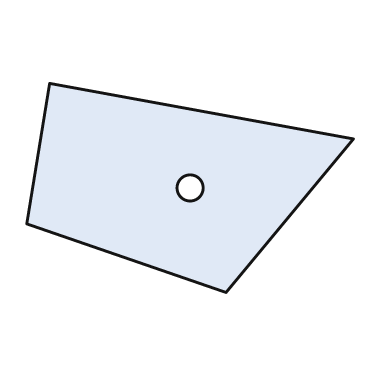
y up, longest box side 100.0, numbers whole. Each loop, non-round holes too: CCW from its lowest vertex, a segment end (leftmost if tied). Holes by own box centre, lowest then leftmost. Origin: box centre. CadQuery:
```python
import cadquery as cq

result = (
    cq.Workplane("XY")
    .moveTo(11.0, -32.0)
    .lineTo(50.0, 15.0)
    .lineTo(-43.0, 32.0)
    .lineTo(-50.0, -11.0)
    .close()
    .moveTo(0.0, 0.0)
    .circle(4.0)
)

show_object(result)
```